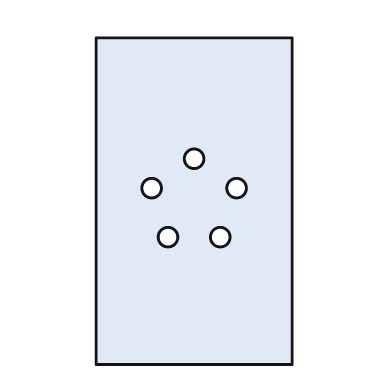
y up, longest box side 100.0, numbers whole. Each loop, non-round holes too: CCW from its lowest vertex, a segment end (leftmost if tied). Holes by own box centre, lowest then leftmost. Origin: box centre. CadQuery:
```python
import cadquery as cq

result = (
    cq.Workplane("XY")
    .moveTo(-30.0, -50.0)
    .lineTo(30.0, -50.0)
    .lineTo(30.0, 50.0)
    .lineTo(-30.0, 50.0)
    .close()
    .moveTo(-8.0, -11.0)
    .circle(3.0)
    .moveTo(8.0, -11.0)
    .circle(3.0)
    .moveTo(-13.0, 4.0)
    .circle(3.0)
    .moveTo(13.0, 4.0)
    .circle(3.0)
    .moveTo(0.0, 13.0)
    .circle(3.0)
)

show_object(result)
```